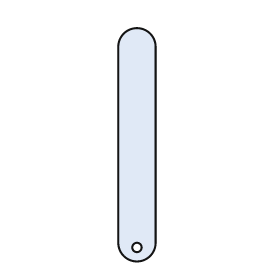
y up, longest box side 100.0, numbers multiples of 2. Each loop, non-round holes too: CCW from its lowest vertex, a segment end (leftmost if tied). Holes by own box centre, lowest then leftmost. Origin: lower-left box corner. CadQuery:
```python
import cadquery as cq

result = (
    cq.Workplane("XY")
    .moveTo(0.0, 8.0)
    .threePointArc((8.0, 0.0), (16.0, 8.0))
    .lineTo(16.0, 92.0)
    .threePointArc((8.0, 100.0), (0.0, 92.0))
    .close()
    .moveTo(8.0, 6.0)
    .circle(2.0)
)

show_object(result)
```